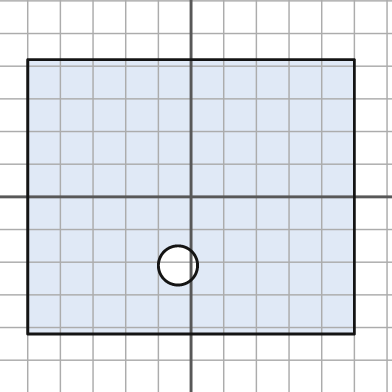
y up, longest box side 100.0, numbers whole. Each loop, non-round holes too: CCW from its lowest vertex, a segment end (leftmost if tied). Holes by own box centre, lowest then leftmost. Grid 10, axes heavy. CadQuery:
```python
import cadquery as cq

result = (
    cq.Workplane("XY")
    .moveTo(-50.0, -42.0)
    .lineTo(50.0, -42.0)
    .lineTo(50.0, 42.0)
    .lineTo(-50.0, 42.0)
    .close()
    .moveTo(-4.0, -21.0)
    .circle(6.0)
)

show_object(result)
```